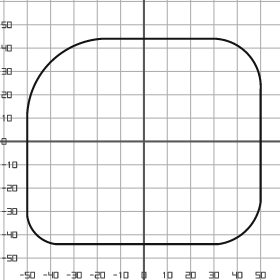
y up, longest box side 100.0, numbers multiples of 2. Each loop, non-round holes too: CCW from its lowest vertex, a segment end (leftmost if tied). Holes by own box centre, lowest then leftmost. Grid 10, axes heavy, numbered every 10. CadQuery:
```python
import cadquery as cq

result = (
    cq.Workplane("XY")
    .moveTo(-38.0, -44.0)
    .lineTo(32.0, -44.0)
    .threePointArc((44.0, -38.0), (50.0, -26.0))
    .lineTo(50.0, 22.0)
    .threePointArc((44.0, 38.0), (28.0, 44.0))
    .lineTo(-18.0, 44.0)
    .threePointArc((-40.0, 34.0), (-50.0, 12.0))
    .lineTo(-50.0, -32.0)
    .threePointArc((-46.0, -40.0), (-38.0, -44.0))
    .close()
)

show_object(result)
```